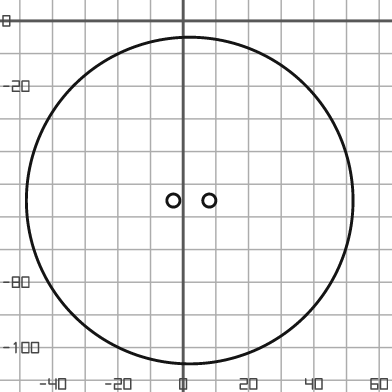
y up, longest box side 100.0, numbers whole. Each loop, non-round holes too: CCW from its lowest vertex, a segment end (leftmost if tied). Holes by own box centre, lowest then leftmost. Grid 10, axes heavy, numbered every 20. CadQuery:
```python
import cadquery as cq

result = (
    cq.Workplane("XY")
    .moveTo(2.0, -55.0)
    .circle(50.0)
    .moveTo(-3.0, -55.0)
    .circle(2.0)
    .moveTo(8.0, -55.0)
    .circle(2.0)
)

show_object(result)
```